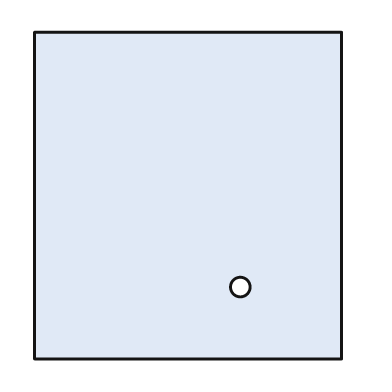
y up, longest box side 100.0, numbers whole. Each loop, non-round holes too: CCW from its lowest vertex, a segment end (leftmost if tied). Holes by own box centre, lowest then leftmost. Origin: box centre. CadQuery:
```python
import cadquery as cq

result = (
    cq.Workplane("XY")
    .moveTo(-47.0, -50.0)
    .lineTo(47.0, -50.0)
    .lineTo(47.0, 50.0)
    .lineTo(-47.0, 50.0)
    .close()
    .moveTo(16.0, -28.0)
    .circle(3.0)
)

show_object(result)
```